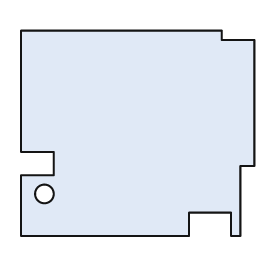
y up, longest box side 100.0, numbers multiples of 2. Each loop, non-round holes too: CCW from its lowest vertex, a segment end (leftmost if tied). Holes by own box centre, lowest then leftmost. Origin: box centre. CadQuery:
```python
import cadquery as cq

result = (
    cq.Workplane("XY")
    .moveTo(-50.0, -44.0)
    .lineTo(22.0, -44.0)
    .lineTo(22.0, -34.0)
    .lineTo(40.0, -34.0)
    .lineTo(40.0, -44.0)
    .lineTo(44.0, -44.0)
    .lineTo(44.0, -14.0)
    .lineTo(50.0, -14.0)
    .lineTo(50.0, 40.0)
    .lineTo(36.0, 40.0)
    .lineTo(36.0, 44.0)
    .lineTo(-50.0, 44.0)
    .lineTo(-50.0, -8.0)
    .lineTo(-36.0, -8.0)
    .lineTo(-36.0, -18.0)
    .lineTo(-50.0, -18.0)
    .close()
    .moveTo(-40.0, -26.0)
    .circle(4.0)
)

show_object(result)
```